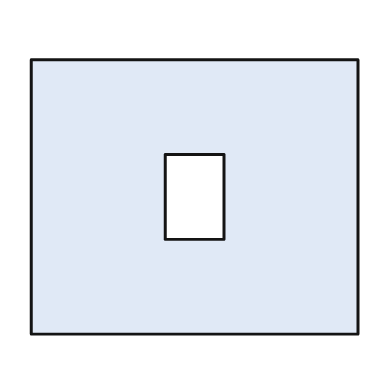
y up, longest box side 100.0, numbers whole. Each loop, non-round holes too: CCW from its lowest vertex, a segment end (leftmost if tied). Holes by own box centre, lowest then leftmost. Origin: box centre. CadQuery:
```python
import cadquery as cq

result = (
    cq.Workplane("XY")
    .moveTo(-50.0, -42.0)
    .lineTo(50.0, -42.0)
    .lineTo(50.0, 42.0)
    .lineTo(-50.0, 42.0)
    .close()
    .moveTo(-9.0, -13.0)
    .lineTo(9.0, -13.0)
    .lineTo(9.0, 13.0)
    .lineTo(-9.0, 13.0)
    .close()
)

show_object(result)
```